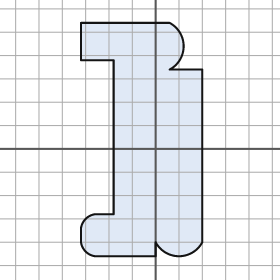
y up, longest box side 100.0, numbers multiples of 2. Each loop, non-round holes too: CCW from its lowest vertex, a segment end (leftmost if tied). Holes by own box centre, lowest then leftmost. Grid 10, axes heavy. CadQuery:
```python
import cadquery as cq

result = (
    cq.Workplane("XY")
    .moveTo(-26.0, -46.0)
    .lineTo(0.0, -46.0)
    .lineTo(0.0, -40.0)
    .threePointArc((10.0, -46.0), (20.0, -40.0))
    .lineTo(20.0, 34.0)
    .lineTo(6.0, 34.0)
    .threePointArc((12.0, 44.0), (6.0, 54.0))
    .lineTo(-32.0, 54.0)
    .lineTo(-32.0, 38.0)
    .lineTo(-18.0, 38.0)
    .lineTo(-18.0, -28.0)
    .lineTo(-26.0, -28.0)
    .threePointArc((-30.0, -30.0), (-32.0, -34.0))
    .lineTo(-32.0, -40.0)
    .threePointArc((-30.0, -44.0), (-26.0, -46.0))
    .close()
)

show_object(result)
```